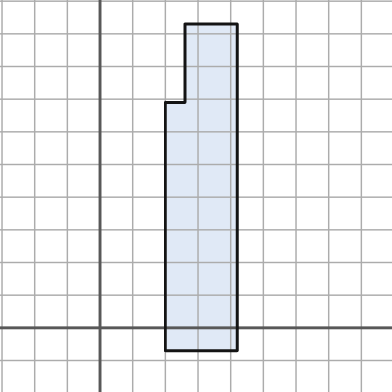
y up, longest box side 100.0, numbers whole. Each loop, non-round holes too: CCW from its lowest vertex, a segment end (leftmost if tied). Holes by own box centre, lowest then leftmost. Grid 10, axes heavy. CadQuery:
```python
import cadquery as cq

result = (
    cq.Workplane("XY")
    .moveTo(20.0, -7.0)
    .lineTo(42.0, -7.0)
    .lineTo(42.0, 93.0)
    .lineTo(26.0, 93.0)
    .lineTo(26.0, 69.0)
    .lineTo(20.0, 69.0)
    .close()
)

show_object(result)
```